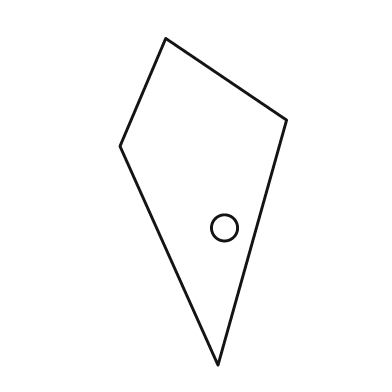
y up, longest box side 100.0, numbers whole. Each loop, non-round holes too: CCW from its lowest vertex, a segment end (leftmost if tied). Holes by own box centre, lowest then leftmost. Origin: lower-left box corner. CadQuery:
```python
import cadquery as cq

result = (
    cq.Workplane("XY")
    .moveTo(30.0, 0.0)
    .lineTo(51.0, 75.0)
    .lineTo(14.0, 100.0)
    .lineTo(0.0, 67.0)
    .close()
    .moveTo(32.0, 42.0)
    .circle(4.0)
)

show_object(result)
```